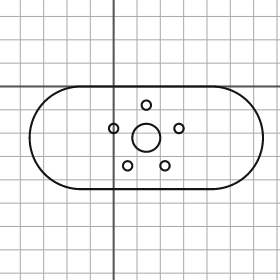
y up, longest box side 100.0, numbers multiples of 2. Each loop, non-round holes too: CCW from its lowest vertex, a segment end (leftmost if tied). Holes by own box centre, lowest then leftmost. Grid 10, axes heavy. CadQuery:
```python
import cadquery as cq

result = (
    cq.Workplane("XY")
    .moveTo(-14.0, -44.0)
    .lineTo(42.0, -44.0)
    .threePointArc((64.0, -22.0), (42.0, 0.0))
    .lineTo(-14.0, 0.0)
    .threePointArc((-36.0, -22.0), (-14.0, -44.0))
    .close()
    .moveTo(6.0, -34.0)
    .circle(2.0)
    .moveTo(22.0, -34.0)
    .circle(2.0)
    .moveTo(14.0, -22.0)
    .circle(6.0)
    .moveTo(0.0, -18.0)
    .circle(2.0)
    .moveTo(28.0, -18.0)
    .circle(2.0)
    .moveTo(14.0, -8.0)
    .circle(2.0)
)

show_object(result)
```